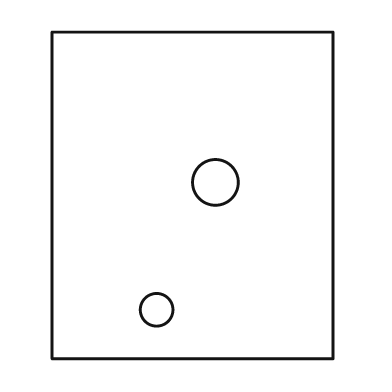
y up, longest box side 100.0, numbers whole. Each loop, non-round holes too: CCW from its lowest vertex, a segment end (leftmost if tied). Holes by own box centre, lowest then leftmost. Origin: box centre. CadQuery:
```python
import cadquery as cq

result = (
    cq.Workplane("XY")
    .moveTo(-43.0, -50.0)
    .lineTo(43.0, -50.0)
    .lineTo(43.0, 50.0)
    .lineTo(-43.0, 50.0)
    .close()
    .moveTo(-11.0, -35.0)
    .circle(5.0)
    .moveTo(7.0, 4.0)
    .circle(7.0)
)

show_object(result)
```